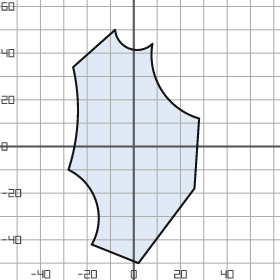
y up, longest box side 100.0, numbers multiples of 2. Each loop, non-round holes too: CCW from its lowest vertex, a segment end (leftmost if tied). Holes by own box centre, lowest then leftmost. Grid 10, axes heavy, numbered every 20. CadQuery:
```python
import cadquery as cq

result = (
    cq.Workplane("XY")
    .moveTo(2.0, -50.0)
    .lineTo(26.0, -18.0)
    .lineTo(28.0, 12.0)
    .threePointArc((12.0, 24.0), (8.0, 44.0))
    .threePointArc((-2.0, 42.0), (-8.0, 50.0))
    .lineTo(-26.0, 34.0)
    .threePointArc((-24.0, 12.0), (-28.0, -10.0))
    .threePointArc((-16.0, -24.0), (-18.0, -42.0))
    .close()
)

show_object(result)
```